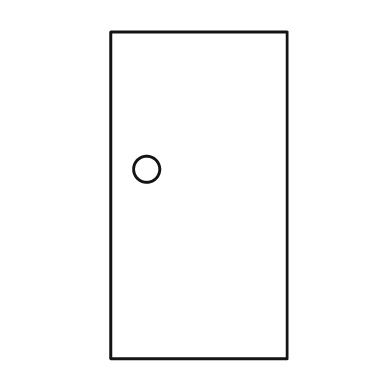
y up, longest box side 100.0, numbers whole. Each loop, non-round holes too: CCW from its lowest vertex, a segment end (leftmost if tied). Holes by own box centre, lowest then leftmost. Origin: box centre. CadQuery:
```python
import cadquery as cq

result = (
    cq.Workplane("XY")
    .moveTo(-27.0, -50.0)
    .lineTo(27.0, -50.0)
    .lineTo(27.0, 50.0)
    .lineTo(-27.0, 50.0)
    .close()
    .moveTo(-16.0, 8.0)
    .circle(4.0)
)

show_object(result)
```